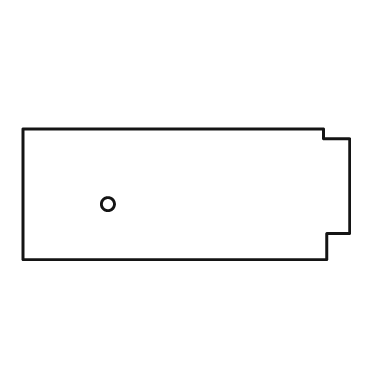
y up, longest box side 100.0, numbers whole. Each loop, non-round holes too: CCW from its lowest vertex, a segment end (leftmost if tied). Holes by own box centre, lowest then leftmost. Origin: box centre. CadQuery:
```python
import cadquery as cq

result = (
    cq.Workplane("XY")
    .moveTo(-50.0, -20.0)
    .lineTo(43.0, -20.0)
    .lineTo(43.0, -12.0)
    .lineTo(50.0, -12.0)
    .lineTo(50.0, 17.0)
    .lineTo(42.0, 17.0)
    .lineTo(42.0, 20.0)
    .lineTo(-50.0, 20.0)
    .close()
    .moveTo(-24.0, -3.0)
    .circle(2.0)
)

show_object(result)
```